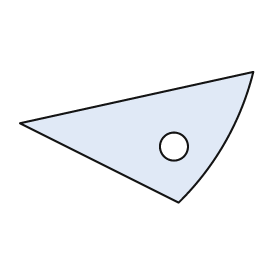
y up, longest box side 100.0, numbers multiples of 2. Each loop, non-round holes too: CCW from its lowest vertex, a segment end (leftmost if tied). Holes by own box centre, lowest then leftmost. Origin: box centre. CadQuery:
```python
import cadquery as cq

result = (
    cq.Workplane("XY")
    .moveTo(18.0, -28.0)
    .threePointArc((38.0, -2.0), (50.0, 28.0))
    .lineTo(-50.0, 6.0)
    .close()
    .moveTo(16.0, -4.0)
    .circle(6.0)
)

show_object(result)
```